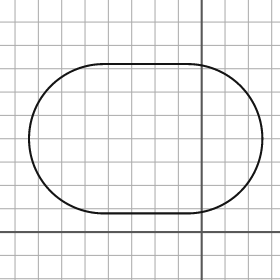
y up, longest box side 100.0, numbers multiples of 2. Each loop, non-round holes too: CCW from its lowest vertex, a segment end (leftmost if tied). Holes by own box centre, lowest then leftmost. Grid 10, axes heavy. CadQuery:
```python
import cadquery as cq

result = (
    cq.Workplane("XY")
    .moveTo(-42.0, 8.0)
    .lineTo(-6.0, 8.0)
    .threePointArc((26.0, 40.0), (-6.0, 72.0))
    .lineTo(-42.0, 72.0)
    .threePointArc((-74.0, 40.0), (-42.0, 8.0))
    .close()
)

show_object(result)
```